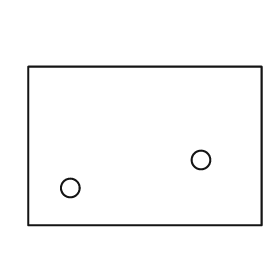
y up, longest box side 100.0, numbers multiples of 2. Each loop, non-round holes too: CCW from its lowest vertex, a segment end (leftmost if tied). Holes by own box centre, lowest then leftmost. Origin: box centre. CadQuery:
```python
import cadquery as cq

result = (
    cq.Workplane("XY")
    .moveTo(-50.0, -34.0)
    .lineTo(50.0, -34.0)
    .lineTo(50.0, 34.0)
    .lineTo(-50.0, 34.0)
    .close()
    .moveTo(-32.0, -18.0)
    .circle(4.0)
    .moveTo(24.0, -6.0)
    .circle(4.0)
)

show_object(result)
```